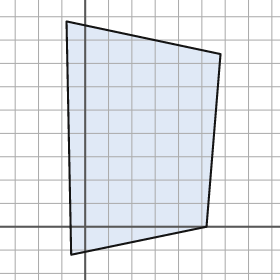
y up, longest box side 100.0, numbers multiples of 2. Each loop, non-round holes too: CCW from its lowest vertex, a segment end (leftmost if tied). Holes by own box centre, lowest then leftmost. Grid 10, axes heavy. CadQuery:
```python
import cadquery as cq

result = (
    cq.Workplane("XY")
    .moveTo(-6.0, -12.0)
    .lineTo(52.0, 0.0)
    .lineTo(58.0, 74.0)
    .lineTo(-8.0, 88.0)
    .close()
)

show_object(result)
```